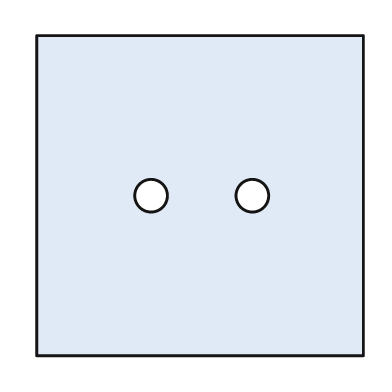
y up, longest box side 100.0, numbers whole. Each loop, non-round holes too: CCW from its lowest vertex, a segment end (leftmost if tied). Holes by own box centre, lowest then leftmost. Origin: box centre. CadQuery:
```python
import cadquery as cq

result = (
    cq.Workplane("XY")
    .moveTo(-50.0, -49.0)
    .lineTo(50.0, -49.0)
    .lineTo(50.0, 49.0)
    .lineTo(-50.0, 49.0)
    .close()
    .moveTo(-15.0, 0.0)
    .circle(5.0)
    .moveTo(16.0, 0.0)
    .circle(5.0)
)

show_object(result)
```